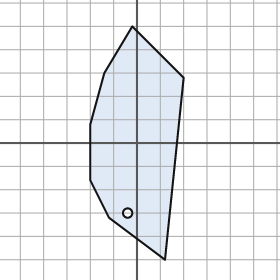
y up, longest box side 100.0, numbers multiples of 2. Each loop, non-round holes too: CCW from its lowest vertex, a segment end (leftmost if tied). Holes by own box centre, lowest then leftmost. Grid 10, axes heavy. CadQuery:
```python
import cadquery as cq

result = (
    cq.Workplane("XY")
    .moveTo(12.0, -50.0)
    .lineTo(20.0, 28.0)
    .lineTo(-2.0, 50.0)
    .lineTo(-14.0, 30.0)
    .lineTo(-20.0, 8.0)
    .lineTo(-20.0, -16.0)
    .lineTo(-12.0, -32.0)
    .close()
    .moveTo(-4.0, -30.0)
    .circle(2.0)
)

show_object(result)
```